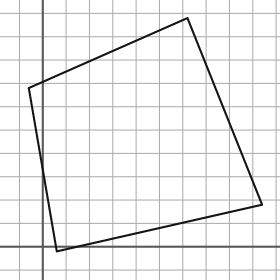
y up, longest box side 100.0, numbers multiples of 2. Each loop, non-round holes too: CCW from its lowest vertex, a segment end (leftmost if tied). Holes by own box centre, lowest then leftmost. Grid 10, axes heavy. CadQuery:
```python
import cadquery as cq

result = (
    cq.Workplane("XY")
    .moveTo(6.0, -2.0)
    .lineTo(94.0, 18.0)
    .lineTo(62.0, 98.0)
    .lineTo(-6.0, 68.0)
    .close()
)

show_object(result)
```